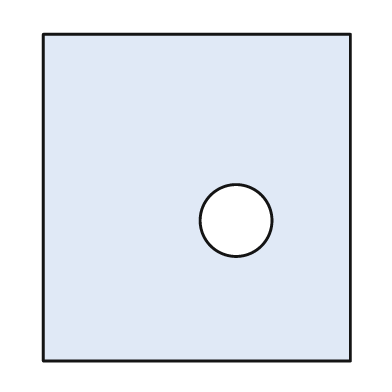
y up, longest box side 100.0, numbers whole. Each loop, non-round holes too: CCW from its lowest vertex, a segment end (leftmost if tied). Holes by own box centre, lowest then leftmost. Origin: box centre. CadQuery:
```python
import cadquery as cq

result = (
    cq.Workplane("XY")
    .moveTo(-47.0, -50.0)
    .lineTo(47.0, -50.0)
    .lineTo(47.0, 50.0)
    .lineTo(-47.0, 50.0)
    .close()
    .moveTo(12.0, -7.0)
    .circle(11.0)
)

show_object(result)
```